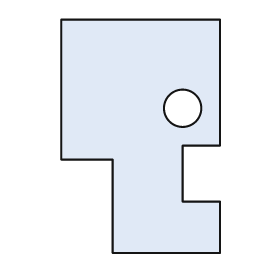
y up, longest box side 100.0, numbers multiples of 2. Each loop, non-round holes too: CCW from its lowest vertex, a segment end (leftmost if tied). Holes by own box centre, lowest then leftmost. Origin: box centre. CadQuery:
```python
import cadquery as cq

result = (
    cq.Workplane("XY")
    .moveTo(-12.0, -50.0)
    .lineTo(34.0, -50.0)
    .lineTo(34.0, -28.0)
    .lineTo(18.0, -28.0)
    .lineTo(18.0, -4.0)
    .lineTo(34.0, -4.0)
    .lineTo(34.0, 50.0)
    .lineTo(-34.0, 50.0)
    .lineTo(-34.0, -10.0)
    .lineTo(-12.0, -10.0)
    .close()
    .moveTo(18.0, 12.0)
    .circle(8.0)
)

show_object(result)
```